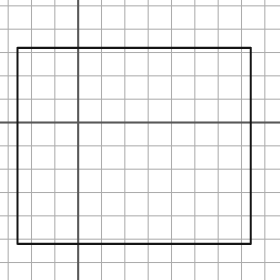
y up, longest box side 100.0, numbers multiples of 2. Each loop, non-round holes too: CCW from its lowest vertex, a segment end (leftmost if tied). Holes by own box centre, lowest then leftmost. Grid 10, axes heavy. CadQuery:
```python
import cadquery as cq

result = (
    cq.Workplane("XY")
    .moveTo(-26.0, -52.0)
    .lineTo(74.0, -52.0)
    .lineTo(74.0, 32.0)
    .lineTo(-26.0, 32.0)
    .close()
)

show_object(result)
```